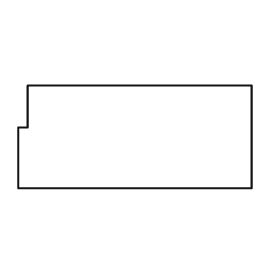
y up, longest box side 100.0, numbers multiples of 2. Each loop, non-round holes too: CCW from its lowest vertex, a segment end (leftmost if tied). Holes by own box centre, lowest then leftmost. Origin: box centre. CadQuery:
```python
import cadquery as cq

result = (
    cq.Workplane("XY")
    .moveTo(-50.0, -22.0)
    .lineTo(50.0, -22.0)
    .lineTo(50.0, 22.0)
    .lineTo(-46.0, 22.0)
    .lineTo(-46.0, 4.0)
    .lineTo(-50.0, 4.0)
    .close()
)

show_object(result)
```